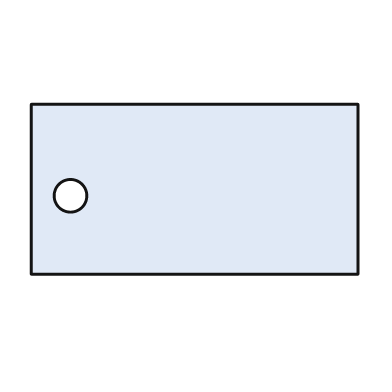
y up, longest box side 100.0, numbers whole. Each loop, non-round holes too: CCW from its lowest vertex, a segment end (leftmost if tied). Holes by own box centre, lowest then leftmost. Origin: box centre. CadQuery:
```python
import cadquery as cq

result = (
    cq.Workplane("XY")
    .moveTo(-50.0, -26.0)
    .lineTo(50.0, -26.0)
    .lineTo(50.0, 26.0)
    .lineTo(-50.0, 26.0)
    .close()
    .moveTo(-38.0, -2.0)
    .circle(5.0)
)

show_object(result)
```